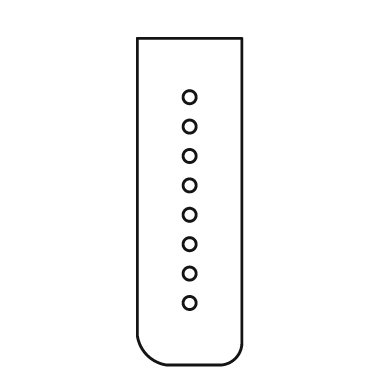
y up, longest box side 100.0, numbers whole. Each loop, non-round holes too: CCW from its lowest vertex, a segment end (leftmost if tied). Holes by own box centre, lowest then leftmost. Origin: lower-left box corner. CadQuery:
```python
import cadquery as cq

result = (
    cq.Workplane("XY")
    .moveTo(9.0, 0.0)
    .lineTo(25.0, 0.0)
    .threePointArc((30.0, 2.0), (32.0, 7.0))
    .lineTo(32.0, 100.0)
    .lineTo(0.0, 100.0)
    .lineTo(0.0, 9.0)
    .threePointArc((3.0, 3.0), (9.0, 0.0))
    .close()
    .moveTo(16.0, 19.0)
    .circle(2.0)
    .moveTo(16.0, 28.0)
    .circle(2.0)
    .moveTo(16.0, 37.0)
    .circle(2.0)
    .moveTo(16.0, 46.0)
    .circle(2.0)
    .moveTo(16.0, 55.0)
    .circle(2.0)
    .moveTo(16.0, 64.0)
    .circle(2.0)
    .moveTo(16.0, 73.0)
    .circle(2.0)
    .moveTo(16.0, 82.0)
    .circle(2.0)
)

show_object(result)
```